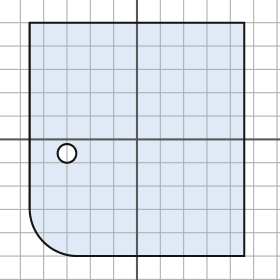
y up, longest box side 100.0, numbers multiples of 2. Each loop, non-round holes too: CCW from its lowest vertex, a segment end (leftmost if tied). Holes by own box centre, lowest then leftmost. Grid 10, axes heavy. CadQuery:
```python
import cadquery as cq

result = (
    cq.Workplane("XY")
    .moveTo(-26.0, -50.0)
    .lineTo(46.0, -50.0)
    .lineTo(46.0, 50.0)
    .lineTo(-46.0, 50.0)
    .lineTo(-46.0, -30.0)
    .threePointArc((-40.0, -44.0), (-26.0, -50.0))
    .close()
    .moveTo(-30.0, -6.0)
    .circle(4.0)
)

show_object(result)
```